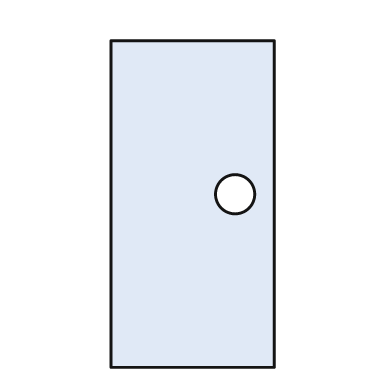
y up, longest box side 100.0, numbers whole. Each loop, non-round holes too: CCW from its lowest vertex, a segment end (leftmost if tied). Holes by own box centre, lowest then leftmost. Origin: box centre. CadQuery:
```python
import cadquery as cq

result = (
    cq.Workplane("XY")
    .moveTo(-25.0, -50.0)
    .lineTo(25.0, -50.0)
    .lineTo(25.0, 50.0)
    .lineTo(-25.0, 50.0)
    .close()
    .moveTo(13.0, 3.0)
    .circle(6.0)
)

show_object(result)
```